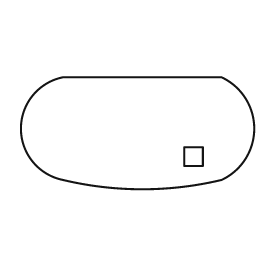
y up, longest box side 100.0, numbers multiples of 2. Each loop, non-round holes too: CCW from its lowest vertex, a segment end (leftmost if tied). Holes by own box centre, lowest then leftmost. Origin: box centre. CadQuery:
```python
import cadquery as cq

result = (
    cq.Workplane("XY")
    .moveTo(-32.0, -20.0)
    .threePointArc((2.0, -24.0), (36.0, -20.0))
    .threePointArc((50.0, 2.0), (36.0, 24.0))
    .lineTo(-32.0, 24.0)
    .threePointArc((-50.0, 2.0), (-32.0, -20.0))
    .close()
    .moveTo(20.0, -14.0)
    .lineTo(28.0, -14.0)
    .lineTo(28.0, -6.0)
    .lineTo(20.0, -6.0)
    .close()
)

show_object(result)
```